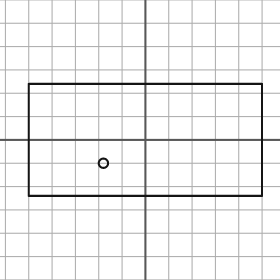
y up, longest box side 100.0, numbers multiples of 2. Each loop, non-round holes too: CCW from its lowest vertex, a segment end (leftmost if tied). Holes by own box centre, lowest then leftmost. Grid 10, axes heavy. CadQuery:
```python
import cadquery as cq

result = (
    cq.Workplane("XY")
    .moveTo(-50.0, -24.0)
    .lineTo(50.0, -24.0)
    .lineTo(50.0, 24.0)
    .lineTo(-50.0, 24.0)
    .close()
    .moveTo(-18.0, -10.0)
    .circle(2.0)
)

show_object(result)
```